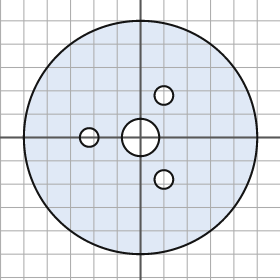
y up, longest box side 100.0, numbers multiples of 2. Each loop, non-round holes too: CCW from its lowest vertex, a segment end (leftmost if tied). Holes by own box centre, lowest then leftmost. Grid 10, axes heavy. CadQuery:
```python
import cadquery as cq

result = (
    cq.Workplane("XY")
    .moveTo(0.0, 0.0)
    .circle(50.0)
    .moveTo(10.0, -18.0)
    .circle(4.0)
    .moveTo(-22.0, 0.0)
    .circle(4.0)
    .moveTo(0.0, 0.0)
    .circle(8.0)
    .moveTo(10.0, 18.0)
    .circle(4.0)
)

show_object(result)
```